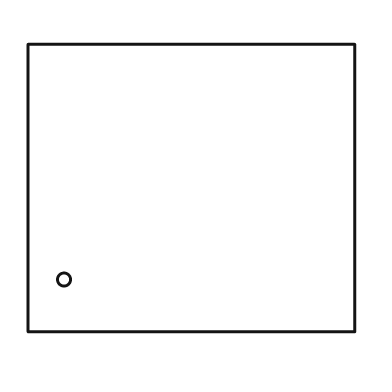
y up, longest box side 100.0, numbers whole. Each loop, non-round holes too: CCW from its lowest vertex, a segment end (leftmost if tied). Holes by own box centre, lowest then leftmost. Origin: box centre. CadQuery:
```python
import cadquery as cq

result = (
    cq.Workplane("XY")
    .moveTo(-50.0, -44.0)
    .lineTo(50.0, -44.0)
    .lineTo(50.0, 44.0)
    .lineTo(-50.0, 44.0)
    .close()
    .moveTo(-39.0, -28.0)
    .circle(2.0)
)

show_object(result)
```